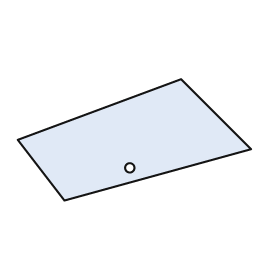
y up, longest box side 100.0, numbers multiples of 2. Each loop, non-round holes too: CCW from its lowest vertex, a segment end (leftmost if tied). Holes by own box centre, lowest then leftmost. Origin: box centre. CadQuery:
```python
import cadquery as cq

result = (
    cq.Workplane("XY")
    .moveTo(-30.0, -26.0)
    .lineTo(50.0, -4.0)
    .lineTo(20.0, 26.0)
    .lineTo(-50.0, 0.0)
    .close()
    .moveTo(-2.0, -12.0)
    .circle(2.0)
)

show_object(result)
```